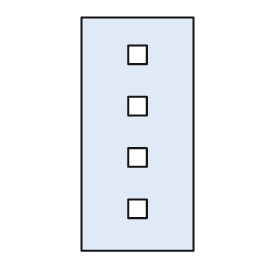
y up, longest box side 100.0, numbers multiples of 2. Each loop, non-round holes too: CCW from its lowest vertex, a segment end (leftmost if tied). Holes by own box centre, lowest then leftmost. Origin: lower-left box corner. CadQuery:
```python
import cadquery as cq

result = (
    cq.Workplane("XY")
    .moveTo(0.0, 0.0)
    .lineTo(48.0, 0.0)
    .lineTo(48.0, 100.0)
    .lineTo(0.0, 100.0)
    .close()
    .moveTo(20.0, 14.0)
    .lineTo(28.0, 14.0)
    .lineTo(28.0, 22.0)
    .lineTo(20.0, 22.0)
    .close()
    .moveTo(20.0, 36.0)
    .lineTo(28.0, 36.0)
    .lineTo(28.0, 44.0)
    .lineTo(20.0, 44.0)
    .close()
    .moveTo(20.0, 58.0)
    .lineTo(28.0, 58.0)
    .lineTo(28.0, 66.0)
    .lineTo(20.0, 66.0)
    .close()
    .moveTo(20.0, 80.0)
    .lineTo(28.0, 80.0)
    .lineTo(28.0, 88.0)
    .lineTo(20.0, 88.0)
    .close()
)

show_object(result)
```